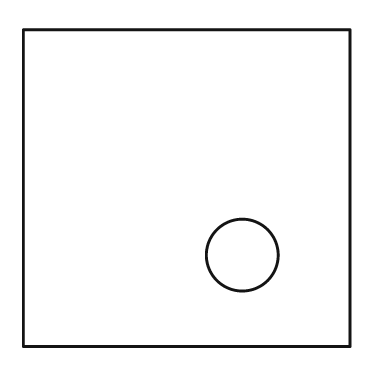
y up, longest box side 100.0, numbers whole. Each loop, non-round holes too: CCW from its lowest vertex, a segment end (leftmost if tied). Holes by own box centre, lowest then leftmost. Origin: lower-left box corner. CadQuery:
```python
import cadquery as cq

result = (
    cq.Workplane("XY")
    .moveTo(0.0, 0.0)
    .lineTo(100.0, 0.0)
    .lineTo(100.0, 97.0)
    .lineTo(0.0, 97.0)
    .close()
    .moveTo(67.0, 28.0)
    .circle(11.0)
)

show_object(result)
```